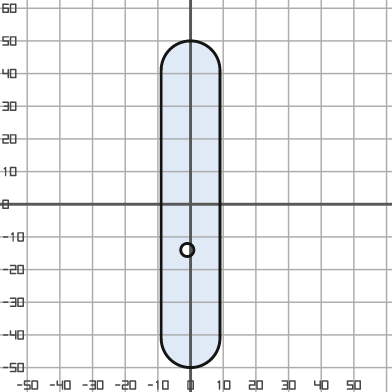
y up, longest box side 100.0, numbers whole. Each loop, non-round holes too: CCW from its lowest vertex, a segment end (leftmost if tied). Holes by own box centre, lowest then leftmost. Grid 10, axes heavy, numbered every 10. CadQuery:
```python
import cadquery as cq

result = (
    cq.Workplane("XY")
    .moveTo(-9.0, -41.0)
    .threePointArc((0.0, -50.0), (9.0, -41.0))
    .lineTo(9.0, 41.0)
    .threePointArc((0.0, 50.0), (-9.0, 41.0))
    .close()
    .moveTo(-1.0, -14.0)
    .circle(2.0)
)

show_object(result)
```